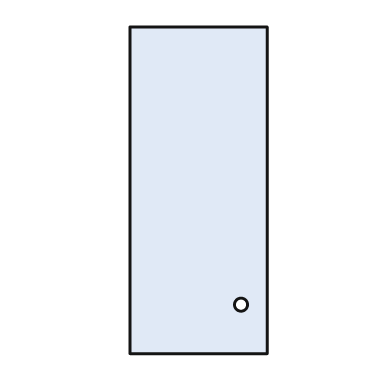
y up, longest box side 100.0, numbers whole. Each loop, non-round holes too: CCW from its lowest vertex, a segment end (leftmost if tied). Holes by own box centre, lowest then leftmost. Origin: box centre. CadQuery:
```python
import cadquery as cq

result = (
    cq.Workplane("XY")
    .moveTo(-21.0, -50.0)
    .lineTo(21.0, -50.0)
    .lineTo(21.0, 50.0)
    .lineTo(-21.0, 50.0)
    .close()
    .moveTo(13.0, -35.0)
    .circle(2.0)
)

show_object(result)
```